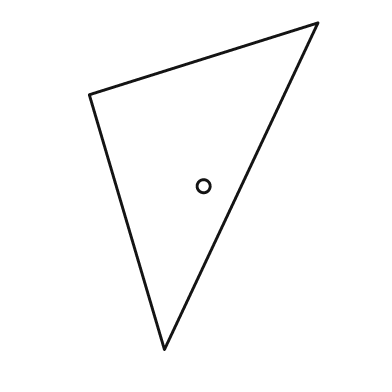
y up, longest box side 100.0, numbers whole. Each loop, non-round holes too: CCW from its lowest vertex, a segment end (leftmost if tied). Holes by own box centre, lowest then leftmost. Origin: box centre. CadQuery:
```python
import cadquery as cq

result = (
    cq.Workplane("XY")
    .moveTo(-12.0, -50.0)
    .lineTo(35.0, 50.0)
    .lineTo(-35.0, 28.0)
    .close()
    .moveTo(0.0, 0.0)
    .circle(2.0)
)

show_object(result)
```